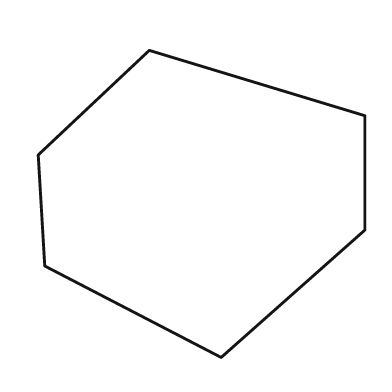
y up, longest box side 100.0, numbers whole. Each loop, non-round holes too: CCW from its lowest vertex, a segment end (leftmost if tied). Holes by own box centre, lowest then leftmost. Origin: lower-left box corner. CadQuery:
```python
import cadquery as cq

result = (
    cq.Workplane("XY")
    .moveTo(56.0, 0.0)
    .lineTo(100.0, 39.0)
    .lineTo(100.0, 74.0)
    .lineTo(34.0, 94.0)
    .lineTo(0.0, 62.0)
    .lineTo(2.0, 28.0)
    .close()
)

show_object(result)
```